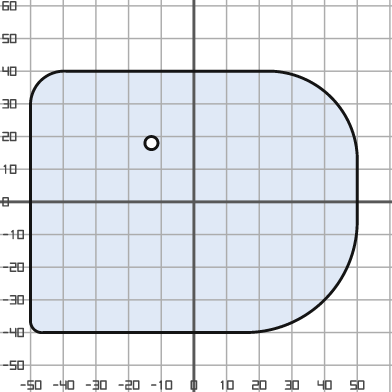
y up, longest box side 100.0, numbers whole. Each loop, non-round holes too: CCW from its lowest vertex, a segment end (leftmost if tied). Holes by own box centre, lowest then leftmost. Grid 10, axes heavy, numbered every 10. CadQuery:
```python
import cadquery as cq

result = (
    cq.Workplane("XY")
    .moveTo(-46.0, -40.0)
    .lineTo(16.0, -40.0)
    .threePointArc((40.0, -30.0), (50.0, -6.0))
    .lineTo(50.0, 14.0)
    .threePointArc((42.0, 32.0), (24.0, 40.0))
    .lineTo(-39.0, 40.0)
    .threePointArc((-47.0, 37.0), (-50.0, 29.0))
    .lineTo(-50.0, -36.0)
    .threePointArc((-49.0, -39.0), (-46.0, -40.0))
    .close()
    .moveTo(-13.0, 18.0)
    .circle(2.0)
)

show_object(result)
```